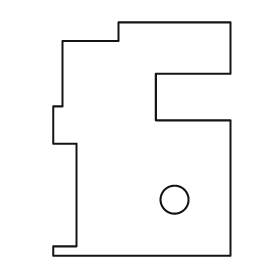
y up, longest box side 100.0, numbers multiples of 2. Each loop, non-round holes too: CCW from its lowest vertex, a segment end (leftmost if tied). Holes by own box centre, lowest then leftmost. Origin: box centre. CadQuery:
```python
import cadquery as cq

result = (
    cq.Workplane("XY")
    .moveTo(-38.0, -50.0)
    .lineTo(38.0, -50.0)
    .lineTo(38.0, 8.0)
    .lineTo(6.0, 8.0)
    .lineTo(6.0, 28.0)
    .lineTo(38.0, 28.0)
    .lineTo(38.0, 50.0)
    .lineTo(-10.0, 50.0)
    .lineTo(-10.0, 42.0)
    .lineTo(-34.0, 42.0)
    .lineTo(-34.0, 14.0)
    .lineTo(-38.0, 14.0)
    .lineTo(-38.0, -2.0)
    .lineTo(-28.0, -2.0)
    .lineTo(-28.0, -46.0)
    .lineTo(-38.0, -46.0)
    .close()
    .moveTo(14.0, -26.0)
    .circle(6.0)
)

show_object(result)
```